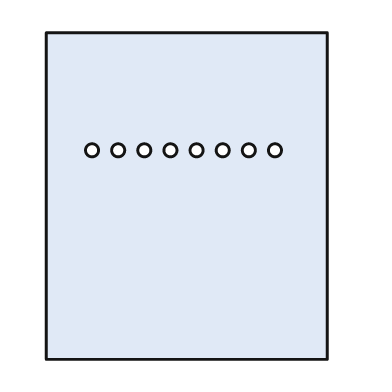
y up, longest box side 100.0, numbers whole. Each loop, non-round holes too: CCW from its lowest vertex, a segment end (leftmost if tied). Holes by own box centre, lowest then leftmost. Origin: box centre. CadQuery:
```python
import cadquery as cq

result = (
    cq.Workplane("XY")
    .moveTo(-43.0, -50.0)
    .lineTo(43.0, -50.0)
    .lineTo(43.0, 50.0)
    .lineTo(-43.0, 50.0)
    .close()
    .moveTo(-29.0, 14.0)
    .circle(2.0)
    .moveTo(-21.0, 14.0)
    .circle(2.0)
    .moveTo(-13.0, 14.0)
    .circle(2.0)
    .moveTo(-5.0, 14.0)
    .circle(2.0)
    .moveTo(3.0, 14.0)
    .circle(2.0)
    .moveTo(11.0, 14.0)
    .circle(2.0)
    .moveTo(19.0, 14.0)
    .circle(2.0)
    .moveTo(27.0, 14.0)
    .circle(2.0)
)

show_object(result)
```